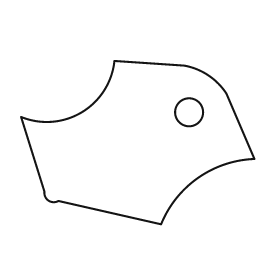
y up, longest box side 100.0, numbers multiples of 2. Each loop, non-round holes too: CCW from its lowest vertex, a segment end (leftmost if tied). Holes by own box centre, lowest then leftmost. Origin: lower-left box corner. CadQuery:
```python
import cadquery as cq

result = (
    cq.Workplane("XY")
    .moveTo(60.0, 0.0)
    .threePointArc((76.0, 20.0), (100.0, 28.0))
    .lineTo(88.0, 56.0)
    .threePointArc((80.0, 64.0), (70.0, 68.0))
    .lineTo(40.0, 70.0)
    .threePointArc((26.0, 48.0), (0.0, 46.0))
    .lineTo(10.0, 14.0)
    .threePointArc((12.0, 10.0), (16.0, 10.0))
    .close()
    .moveTo(72.0, 48.0)
    .circle(6.0)
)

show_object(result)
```